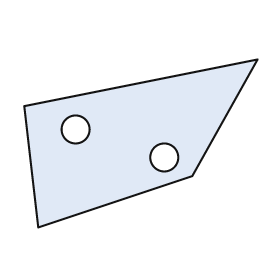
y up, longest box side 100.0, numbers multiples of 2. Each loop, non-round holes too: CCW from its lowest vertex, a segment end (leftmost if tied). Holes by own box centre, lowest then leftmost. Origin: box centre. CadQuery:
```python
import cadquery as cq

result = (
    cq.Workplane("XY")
    .moveTo(-44.0, -36.0)
    .lineTo(22.0, -14.0)
    .lineTo(50.0, 36.0)
    .lineTo(-50.0, 16.0)
    .close()
    .moveTo(10.0, -6.0)
    .circle(6.0)
    .moveTo(-28.0, 6.0)
    .circle(6.0)
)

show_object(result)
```